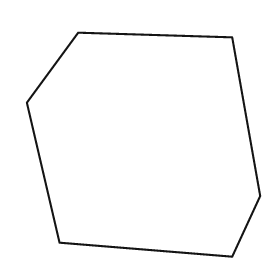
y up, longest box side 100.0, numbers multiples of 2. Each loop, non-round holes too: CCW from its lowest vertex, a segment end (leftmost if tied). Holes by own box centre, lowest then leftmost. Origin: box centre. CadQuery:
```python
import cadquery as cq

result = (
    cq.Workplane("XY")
    .moveTo(38.0, -48.0)
    .lineTo(50.0, -22.0)
    .lineTo(38.0, 46.0)
    .lineTo(-28.0, 48.0)
    .lineTo(-50.0, 18.0)
    .lineTo(-36.0, -42.0)
    .close()
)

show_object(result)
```